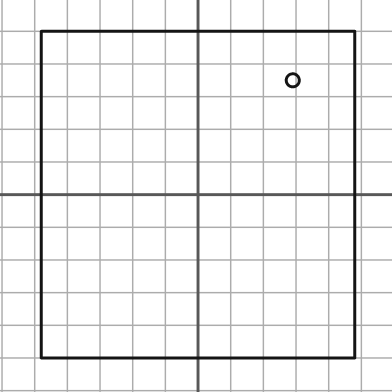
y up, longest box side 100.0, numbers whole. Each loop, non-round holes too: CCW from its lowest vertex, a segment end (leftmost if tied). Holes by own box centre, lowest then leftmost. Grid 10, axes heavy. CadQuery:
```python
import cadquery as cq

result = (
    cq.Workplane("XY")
    .moveTo(-48.0, -50.0)
    .lineTo(48.0, -50.0)
    .lineTo(48.0, 50.0)
    .lineTo(-48.0, 50.0)
    .close()
    .moveTo(29.0, 35.0)
    .circle(2.0)
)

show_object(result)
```